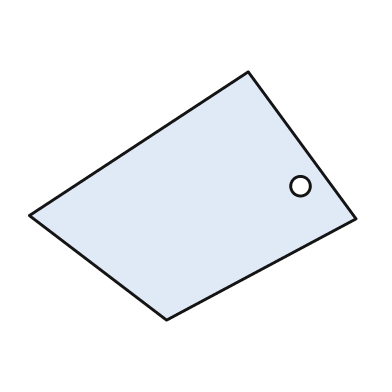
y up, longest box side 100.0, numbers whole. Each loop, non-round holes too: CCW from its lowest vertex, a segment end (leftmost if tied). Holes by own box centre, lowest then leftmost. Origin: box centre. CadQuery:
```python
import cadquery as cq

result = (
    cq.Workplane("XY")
    .moveTo(-8.0, -38.0)
    .lineTo(50.0, -7.0)
    .lineTo(17.0, 38.0)
    .lineTo(-50.0, -6.0)
    .close()
    .moveTo(33.0, 3.0)
    .circle(3.0)
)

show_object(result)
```